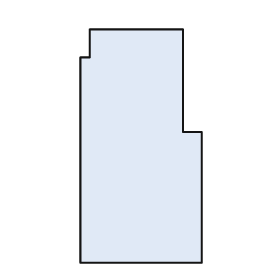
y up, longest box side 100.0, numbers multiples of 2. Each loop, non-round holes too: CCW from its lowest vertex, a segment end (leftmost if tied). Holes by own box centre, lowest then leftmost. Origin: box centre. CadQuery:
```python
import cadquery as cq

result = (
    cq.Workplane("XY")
    .moveTo(-26.0, -50.0)
    .lineTo(26.0, -50.0)
    .lineTo(26.0, 6.0)
    .lineTo(18.0, 6.0)
    .lineTo(18.0, 50.0)
    .lineTo(-22.0, 50.0)
    .lineTo(-22.0, 38.0)
    .lineTo(-26.0, 38.0)
    .close()
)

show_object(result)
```